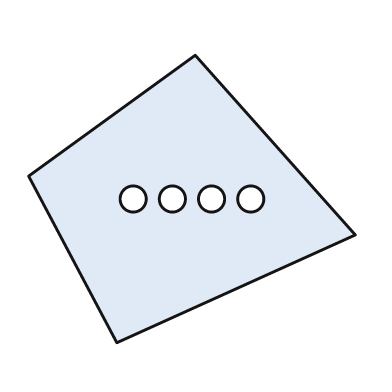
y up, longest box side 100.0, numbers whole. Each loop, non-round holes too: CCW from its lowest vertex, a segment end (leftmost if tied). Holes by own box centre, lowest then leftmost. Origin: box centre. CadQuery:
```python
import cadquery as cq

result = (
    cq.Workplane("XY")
    .moveTo(-23.0, -44.0)
    .lineTo(50.0, -11.0)
    .lineTo(1.0, 44.0)
    .lineTo(-50.0, 7.0)
    .close()
    .moveTo(-18.0, 0.0)
    .circle(4.0)
    .moveTo(-6.0, 0.0)
    .circle(4.0)
    .moveTo(6.0, 0.0)
    .circle(4.0)
    .moveTo(18.0, 0.0)
    .circle(4.0)
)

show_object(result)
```